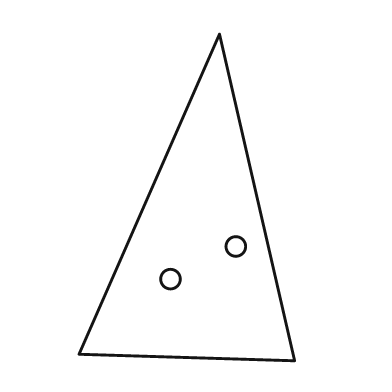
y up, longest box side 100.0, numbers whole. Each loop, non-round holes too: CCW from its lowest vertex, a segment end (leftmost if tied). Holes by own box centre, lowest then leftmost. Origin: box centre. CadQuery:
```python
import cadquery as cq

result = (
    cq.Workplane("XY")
    .moveTo(33.0, -50.0)
    .lineTo(10.0, 50.0)
    .lineTo(-33.0, -48.0)
    .close()
    .moveTo(-5.0, -25.0)
    .circle(3.0)
    .moveTo(15.0, -15.0)
    .circle(3.0)
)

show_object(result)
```